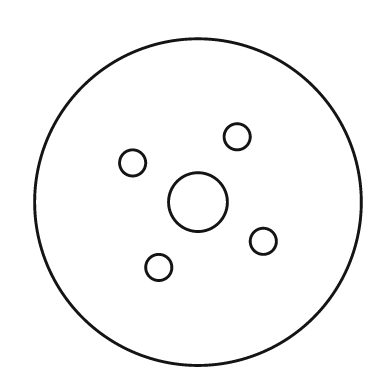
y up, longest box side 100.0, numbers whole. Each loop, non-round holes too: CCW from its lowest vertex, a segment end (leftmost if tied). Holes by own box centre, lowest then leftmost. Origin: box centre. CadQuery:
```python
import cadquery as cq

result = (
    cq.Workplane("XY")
    .moveTo(0.0, 0.0)
    .circle(50.0)
    .moveTo(-12.0, -20.0)
    .circle(4.0)
    .moveTo(20.0, -12.0)
    .circle(4.0)
    .moveTo(0.0, 0.0)
    .circle(9.0)
    .moveTo(-20.0, 12.0)
    .circle(4.0)
    .moveTo(12.0, 20.0)
    .circle(4.0)
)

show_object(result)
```